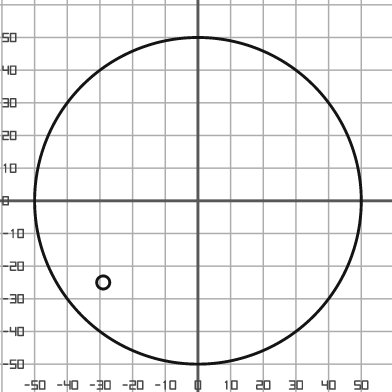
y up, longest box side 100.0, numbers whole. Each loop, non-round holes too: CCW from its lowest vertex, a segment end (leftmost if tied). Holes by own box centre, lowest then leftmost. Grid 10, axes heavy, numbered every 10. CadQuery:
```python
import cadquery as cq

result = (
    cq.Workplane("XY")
    .moveTo(0.0, 0.0)
    .circle(50.0)
    .moveTo(-29.0, -25.0)
    .circle(2.0)
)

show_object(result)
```